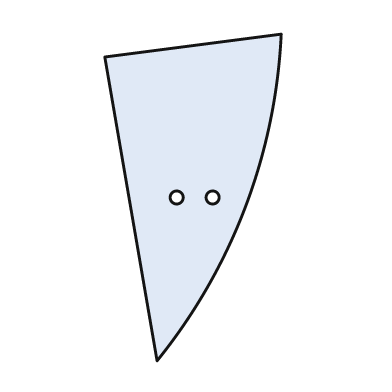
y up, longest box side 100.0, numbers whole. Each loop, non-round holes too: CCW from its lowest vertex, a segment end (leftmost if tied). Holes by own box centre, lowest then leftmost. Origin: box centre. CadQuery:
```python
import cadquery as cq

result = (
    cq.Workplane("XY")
    .moveTo(-11.0, -50.0)
    .threePointArc((16.0, -3.0), (27.0, 50.0))
    .lineTo(-27.0, 43.0)
    .close()
    .moveTo(-5.0, 0.0)
    .circle(2.0)
    .moveTo(6.0, 0.0)
    .circle(2.0)
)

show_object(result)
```